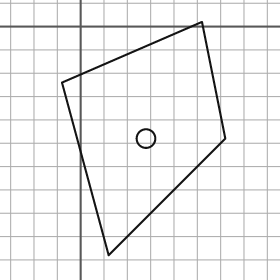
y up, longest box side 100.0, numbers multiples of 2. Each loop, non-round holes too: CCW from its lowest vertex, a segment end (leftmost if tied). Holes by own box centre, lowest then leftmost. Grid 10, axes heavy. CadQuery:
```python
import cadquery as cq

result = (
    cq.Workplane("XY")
    .moveTo(12.0, -98.0)
    .lineTo(62.0, -48.0)
    .lineTo(52.0, 2.0)
    .lineTo(-8.0, -24.0)
    .close()
    .moveTo(28.0, -48.0)
    .circle(4.0)
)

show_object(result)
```